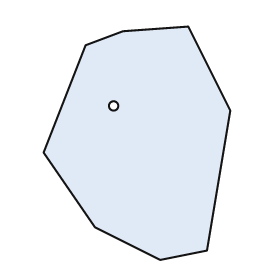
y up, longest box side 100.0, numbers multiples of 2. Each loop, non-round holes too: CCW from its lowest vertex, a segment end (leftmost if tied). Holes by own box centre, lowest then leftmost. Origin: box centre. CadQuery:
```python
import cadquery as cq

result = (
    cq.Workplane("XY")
    .moveTo(10.0, -50.0)
    .lineTo(30.0, -46.0)
    .lineTo(40.0, 14.0)
    .lineTo(22.0, 50.0)
    .lineTo(-6.0, 48.0)
    .lineTo(-22.0, 42.0)
    .lineTo(-40.0, -4.0)
    .lineTo(-18.0, -36.0)
    .close()
    .moveTo(-10.0, 16.0)
    .circle(2.0)
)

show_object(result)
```